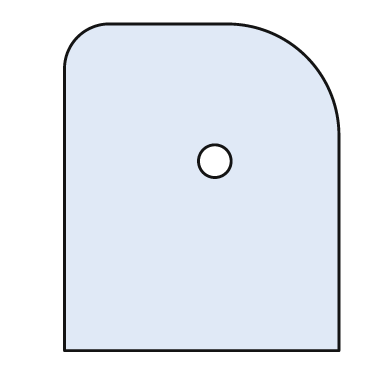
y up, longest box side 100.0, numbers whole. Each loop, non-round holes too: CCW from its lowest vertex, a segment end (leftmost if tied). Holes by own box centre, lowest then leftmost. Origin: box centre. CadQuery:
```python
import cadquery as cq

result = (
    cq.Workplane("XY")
    .moveTo(-42.0, -50.0)
    .lineTo(42.0, -50.0)
    .lineTo(42.0, 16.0)
    .threePointArc((32.0, 40.0), (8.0, 50.0))
    .lineTo(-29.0, 50.0)
    .threePointArc((-38.0, 46.0), (-42.0, 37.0))
    .close()
    .moveTo(4.0, 8.0)
    .circle(5.0)
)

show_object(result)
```